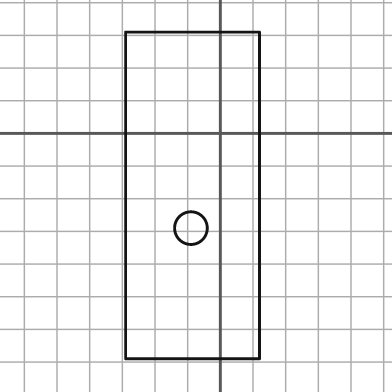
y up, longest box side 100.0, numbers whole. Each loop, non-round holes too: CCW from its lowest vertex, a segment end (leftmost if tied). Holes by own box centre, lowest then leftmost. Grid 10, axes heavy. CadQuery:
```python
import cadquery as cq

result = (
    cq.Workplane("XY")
    .moveTo(-29.0, -69.0)
    .lineTo(12.0, -69.0)
    .lineTo(12.0, 31.0)
    .lineTo(-29.0, 31.0)
    .close()
    .moveTo(-9.0, -29.0)
    .circle(5.0)
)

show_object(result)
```